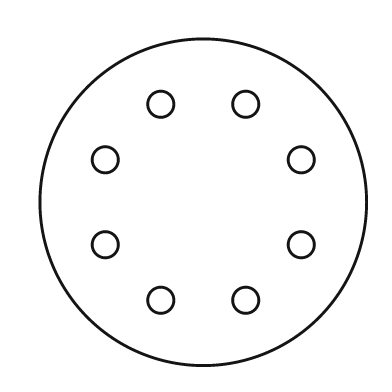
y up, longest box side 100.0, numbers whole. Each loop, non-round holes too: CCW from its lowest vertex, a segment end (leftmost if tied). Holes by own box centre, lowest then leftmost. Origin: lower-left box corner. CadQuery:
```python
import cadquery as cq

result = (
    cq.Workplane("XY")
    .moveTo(50.0, 50.0)
    .circle(50.0)
    .moveTo(37.0, 20.0)
    .circle(4.0)
    .moveTo(63.0, 20.0)
    .circle(4.0)
    .moveTo(20.0, 37.0)
    .circle(4.0)
    .moveTo(80.0, 37.0)
    .circle(4.0)
    .moveTo(20.0, 63.0)
    .circle(4.0)
    .moveTo(80.0, 63.0)
    .circle(4.0)
    .moveTo(37.0, 80.0)
    .circle(4.0)
    .moveTo(63.0, 80.0)
    .circle(4.0)
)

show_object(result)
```